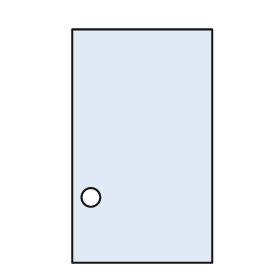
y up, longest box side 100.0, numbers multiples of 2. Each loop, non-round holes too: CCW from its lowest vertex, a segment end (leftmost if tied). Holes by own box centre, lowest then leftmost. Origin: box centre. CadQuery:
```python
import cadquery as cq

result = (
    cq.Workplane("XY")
    .moveTo(-30.0, -50.0)
    .lineTo(30.0, -50.0)
    .lineTo(30.0, 50.0)
    .lineTo(-30.0, 50.0)
    .close()
    .moveTo(-22.0, -22.0)
    .circle(4.0)
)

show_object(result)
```